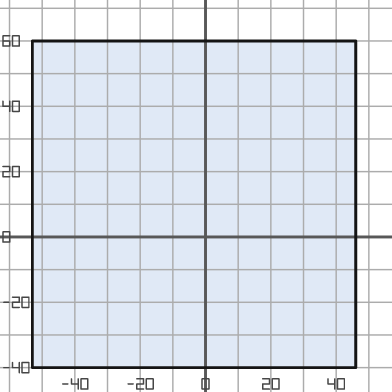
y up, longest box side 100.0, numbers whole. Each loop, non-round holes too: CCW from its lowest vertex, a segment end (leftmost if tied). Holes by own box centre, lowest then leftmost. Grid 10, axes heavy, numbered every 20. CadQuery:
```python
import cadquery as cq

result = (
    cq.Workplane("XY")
    .moveTo(-53.0, -40.0)
    .lineTo(46.0, -40.0)
    .lineTo(46.0, 60.0)
    .lineTo(-53.0, 60.0)
    .close()
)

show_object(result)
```